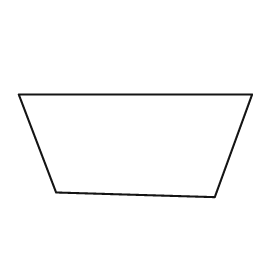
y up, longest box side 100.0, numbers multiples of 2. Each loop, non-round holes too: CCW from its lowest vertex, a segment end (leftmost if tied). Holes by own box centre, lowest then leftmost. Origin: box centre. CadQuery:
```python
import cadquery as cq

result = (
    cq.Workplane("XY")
    .moveTo(34.0, -22.0)
    .lineTo(50.0, 22.0)
    .lineTo(-50.0, 22.0)
    .lineTo(-34.0, -20.0)
    .close()
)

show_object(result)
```